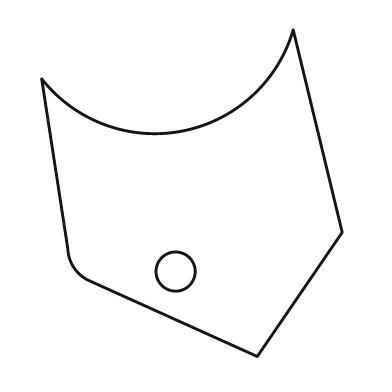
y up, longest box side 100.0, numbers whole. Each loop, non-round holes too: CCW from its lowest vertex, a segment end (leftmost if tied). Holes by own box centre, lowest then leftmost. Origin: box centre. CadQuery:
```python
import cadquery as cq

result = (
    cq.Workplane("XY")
    .moveTo(20.0, -50.0)
    .lineTo(46.0, -12.0)
    .lineTo(31.0, 50.0)
    .threePointArc((-3.0, 19.0), (-46.0, 35.0))
    .lineTo(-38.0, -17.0)
    .threePointArc((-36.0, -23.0), (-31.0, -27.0))
    .close()
    .moveTo(-5.0, -24.0)
    .circle(6.0)
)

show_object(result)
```